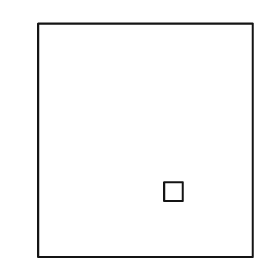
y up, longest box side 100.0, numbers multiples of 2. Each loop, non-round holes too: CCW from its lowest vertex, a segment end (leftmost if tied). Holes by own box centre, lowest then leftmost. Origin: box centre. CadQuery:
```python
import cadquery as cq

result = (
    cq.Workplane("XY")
    .moveTo(-46.0, -50.0)
    .lineTo(46.0, -50.0)
    .lineTo(46.0, 50.0)
    .lineTo(-46.0, 50.0)
    .close()
    .moveTo(8.0, -26.0)
    .lineTo(16.0, -26.0)
    .lineTo(16.0, -18.0)
    .lineTo(8.0, -18.0)
    .close()
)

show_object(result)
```